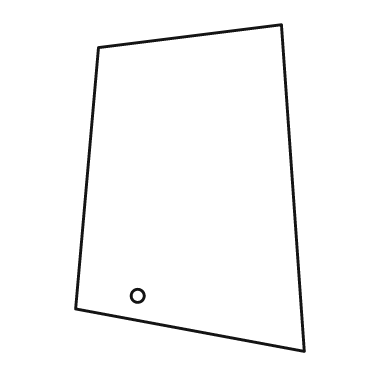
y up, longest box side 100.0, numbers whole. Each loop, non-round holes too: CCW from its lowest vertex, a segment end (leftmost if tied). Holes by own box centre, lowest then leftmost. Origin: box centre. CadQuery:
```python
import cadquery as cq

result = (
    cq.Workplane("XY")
    .moveTo(35.0, -50.0)
    .lineTo(28.0, 50.0)
    .lineTo(-28.0, 43.0)
    .lineTo(-35.0, -37.0)
    .close()
    .moveTo(-16.0, -33.0)
    .circle(2.0)
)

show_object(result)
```